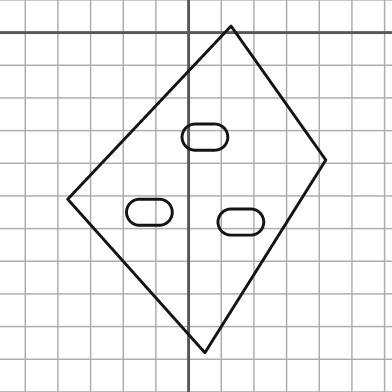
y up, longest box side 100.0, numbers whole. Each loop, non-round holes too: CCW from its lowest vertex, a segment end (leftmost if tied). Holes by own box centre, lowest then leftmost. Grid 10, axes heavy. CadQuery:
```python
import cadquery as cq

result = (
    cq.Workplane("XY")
    .moveTo(5.0, -98.0)
    .lineTo(42.0, -39.0)
    .lineTo(13.0, 2.0)
    .lineTo(-37.0, -51.0)
    .close()
    .moveTo(13.0, -62.0)
    .lineTo(19.0, -62.0)
    .threePointArc((23.0, -58.0), (19.0, -54.0))
    .lineTo(13.0, -54.0)
    .threePointArc((9.0, -58.0), (13.0, -62.0))
    .close()
    .moveTo(-15.0, -59.0)
    .lineTo(-9.0, -59.0)
    .threePointArc((-5.0, -55.0), (-9.0, -51.0))
    .lineTo(-15.0, -51.0)
    .threePointArc((-19.0, -55.0), (-15.0, -59.0))
    .close()
    .moveTo(2.0, -36.0)
    .lineTo(8.0, -36.0)
    .threePointArc((12.0, -32.0), (8.0, -28.0))
    .lineTo(2.0, -28.0)
    .threePointArc((-2.0, -32.0), (2.0, -36.0))
    .close()
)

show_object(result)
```